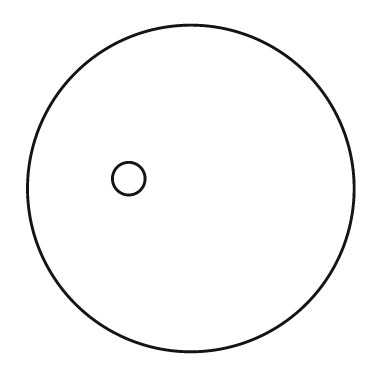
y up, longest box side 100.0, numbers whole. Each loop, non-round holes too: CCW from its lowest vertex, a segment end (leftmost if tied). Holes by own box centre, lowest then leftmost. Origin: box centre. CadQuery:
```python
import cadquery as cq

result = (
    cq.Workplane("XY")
    .moveTo(0.0, 0.0)
    .circle(50.0)
    .moveTo(-19.0, 3.0)
    .circle(5.0)
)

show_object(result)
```